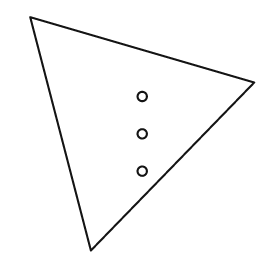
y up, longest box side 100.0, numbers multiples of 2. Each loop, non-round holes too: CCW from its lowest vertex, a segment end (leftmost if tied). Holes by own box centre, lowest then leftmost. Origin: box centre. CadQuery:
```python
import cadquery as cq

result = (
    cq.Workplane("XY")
    .moveTo(-22.0, -50.0)
    .lineTo(48.0, 22.0)
    .lineTo(-48.0, 50.0)
    .close()
    .moveTo(0.0, -16.0)
    .circle(2.0)
    .moveTo(0.0, 0.0)
    .circle(2.0)
    .moveTo(0.0, 16.0)
    .circle(2.0)
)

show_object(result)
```